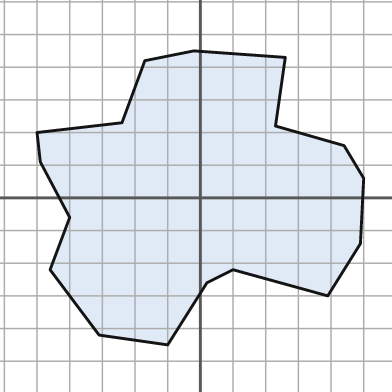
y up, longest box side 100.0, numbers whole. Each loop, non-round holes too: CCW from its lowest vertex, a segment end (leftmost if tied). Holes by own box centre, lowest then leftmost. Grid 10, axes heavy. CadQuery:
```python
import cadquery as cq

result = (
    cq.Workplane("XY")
    .moveTo(-10.0, -45.0)
    .lineTo(2.0, -26.0)
    .lineTo(10.0, -22.0)
    .lineTo(39.0, -30.0)
    .lineTo(49.0, -14.0)
    .lineTo(50.0, 6.0)
    .lineTo(44.0, 16.0)
    .lineTo(23.0, 22.0)
    .lineTo(26.0, 43.0)
    .lineTo(-2.0, 45.0)
    .lineTo(-17.0, 42.0)
    .lineTo(-24.0, 23.0)
    .lineTo(-50.0, 20.0)
    .lineTo(-49.0, 11.0)
    .lineTo(-40.0, -6.0)
    .lineTo(-46.0, -22.0)
    .lineTo(-31.0, -42.0)
    .close()
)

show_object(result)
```